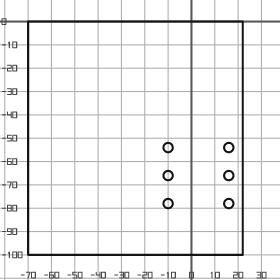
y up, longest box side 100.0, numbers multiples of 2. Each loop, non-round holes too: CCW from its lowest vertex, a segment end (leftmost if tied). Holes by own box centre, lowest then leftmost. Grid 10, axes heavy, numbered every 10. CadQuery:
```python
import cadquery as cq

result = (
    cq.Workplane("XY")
    .moveTo(-70.0, -100.0)
    .lineTo(22.0, -100.0)
    .lineTo(22.0, 0.0)
    .lineTo(-70.0, 0.0)
    .close()
    .moveTo(-10.0, -78.0)
    .circle(2.0)
    .moveTo(16.0, -78.0)
    .circle(2.0)
    .moveTo(-10.0, -66.0)
    .circle(2.0)
    .moveTo(16.0, -66.0)
    .circle(2.0)
    .moveTo(-10.0, -54.0)
    .circle(2.0)
    .moveTo(16.0, -54.0)
    .circle(2.0)
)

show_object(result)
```